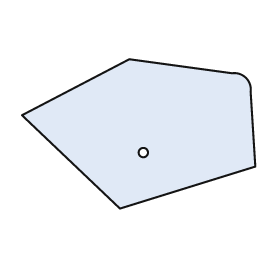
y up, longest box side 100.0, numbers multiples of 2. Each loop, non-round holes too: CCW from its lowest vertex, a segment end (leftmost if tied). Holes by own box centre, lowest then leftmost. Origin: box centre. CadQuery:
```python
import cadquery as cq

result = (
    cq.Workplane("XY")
    .moveTo(-8.0, -32.0)
    .lineTo(50.0, -14.0)
    .lineTo(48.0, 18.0)
    .threePointArc((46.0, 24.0), (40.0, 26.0))
    .lineTo(-4.0, 32.0)
    .lineTo(-50.0, 8.0)
    .close()
    .moveTo(2.0, -8.0)
    .circle(2.0)
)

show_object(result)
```